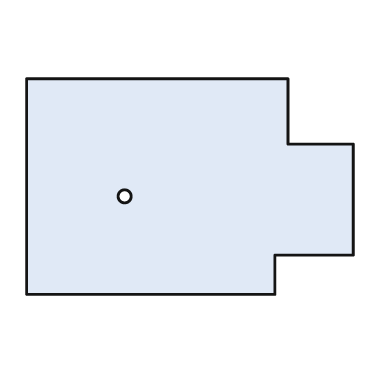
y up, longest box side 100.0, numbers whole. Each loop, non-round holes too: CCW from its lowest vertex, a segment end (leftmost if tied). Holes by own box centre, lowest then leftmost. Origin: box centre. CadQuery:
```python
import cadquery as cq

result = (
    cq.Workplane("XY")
    .moveTo(-50.0, -33.0)
    .lineTo(26.0, -33.0)
    .lineTo(26.0, -21.0)
    .lineTo(50.0, -21.0)
    .lineTo(50.0, 13.0)
    .lineTo(30.0, 13.0)
    .lineTo(30.0, 33.0)
    .lineTo(-50.0, 33.0)
    .close()
    .moveTo(-20.0, -3.0)
    .circle(2.0)
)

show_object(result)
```